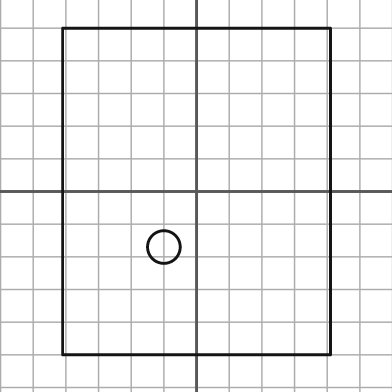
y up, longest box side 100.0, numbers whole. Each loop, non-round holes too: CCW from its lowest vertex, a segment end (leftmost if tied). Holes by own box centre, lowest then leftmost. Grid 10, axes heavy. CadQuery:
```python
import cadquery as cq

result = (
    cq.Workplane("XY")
    .moveTo(-41.0, -50.0)
    .lineTo(41.0, -50.0)
    .lineTo(41.0, 50.0)
    .lineTo(-41.0, 50.0)
    .close()
    .moveTo(-10.0, -17.0)
    .circle(5.0)
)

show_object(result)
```